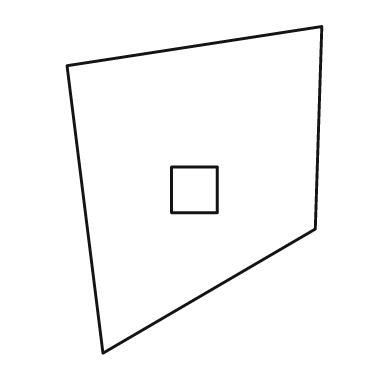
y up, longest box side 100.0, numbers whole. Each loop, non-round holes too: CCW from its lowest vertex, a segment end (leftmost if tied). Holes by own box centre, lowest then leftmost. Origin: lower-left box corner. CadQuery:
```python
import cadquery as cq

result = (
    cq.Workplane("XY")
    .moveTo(11.0, 0.0)
    .lineTo(76.0, 38.0)
    .lineTo(78.0, 100.0)
    .lineTo(0.0, 88.0)
    .close()
    .moveTo(32.0, 43.0)
    .lineTo(46.0, 43.0)
    .lineTo(46.0, 57.0)
    .lineTo(32.0, 57.0)
    .close()
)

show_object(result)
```